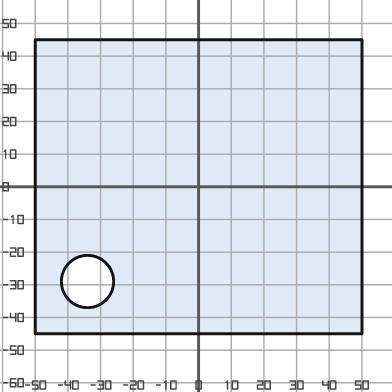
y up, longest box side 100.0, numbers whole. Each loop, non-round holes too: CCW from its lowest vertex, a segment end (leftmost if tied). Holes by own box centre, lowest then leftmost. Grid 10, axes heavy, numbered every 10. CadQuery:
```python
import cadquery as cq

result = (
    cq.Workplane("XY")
    .moveTo(-50.0, -45.0)
    .lineTo(50.0, -45.0)
    .lineTo(50.0, 45.0)
    .lineTo(-50.0, 45.0)
    .close()
    .moveTo(-34.0, -29.0)
    .circle(8.0)
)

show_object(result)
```